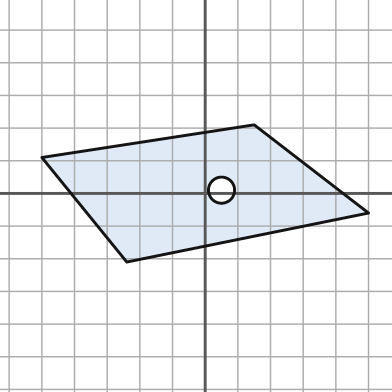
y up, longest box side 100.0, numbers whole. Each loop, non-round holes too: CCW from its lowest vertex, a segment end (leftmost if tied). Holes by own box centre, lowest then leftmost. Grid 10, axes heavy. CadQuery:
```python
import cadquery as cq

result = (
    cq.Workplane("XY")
    .moveTo(-24.0, -21.0)
    .lineTo(50.0, -6.0)
    .lineTo(15.0, 21.0)
    .lineTo(-50.0, 11.0)
    .close()
    .moveTo(5.0, 1.0)
    .circle(4.0)
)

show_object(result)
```